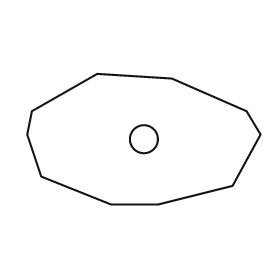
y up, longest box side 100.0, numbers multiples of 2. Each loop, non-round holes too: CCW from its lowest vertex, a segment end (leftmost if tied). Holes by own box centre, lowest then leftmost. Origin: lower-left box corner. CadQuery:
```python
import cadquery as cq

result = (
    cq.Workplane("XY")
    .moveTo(36.0, 0.0)
    .lineTo(56.0, 0.0)
    .lineTo(88.0, 8.0)
    .lineTo(100.0, 30.0)
    .lineTo(94.0, 40.0)
    .lineTo(62.0, 54.0)
    .lineTo(30.0, 56.0)
    .lineTo(2.0, 40.0)
    .lineTo(0.0, 30.0)
    .lineTo(6.0, 12.0)
    .close()
    .moveTo(50.0, 28.0)
    .circle(6.0)
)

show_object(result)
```